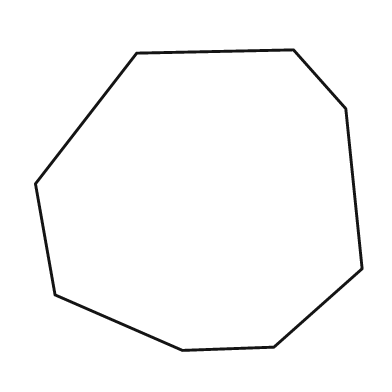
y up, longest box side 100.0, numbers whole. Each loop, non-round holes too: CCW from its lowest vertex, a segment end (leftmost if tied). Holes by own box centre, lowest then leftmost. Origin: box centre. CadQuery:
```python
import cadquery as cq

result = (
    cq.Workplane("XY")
    .moveTo(-5.0, -46.0)
    .lineTo(23.0, -45.0)
    .lineTo(50.0, -21.0)
    .lineTo(45.0, 28.0)
    .lineTo(29.0, 46.0)
    .lineTo(-19.0, 45.0)
    .lineTo(-50.0, 5.0)
    .lineTo(-44.0, -29.0)
    .close()
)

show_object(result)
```